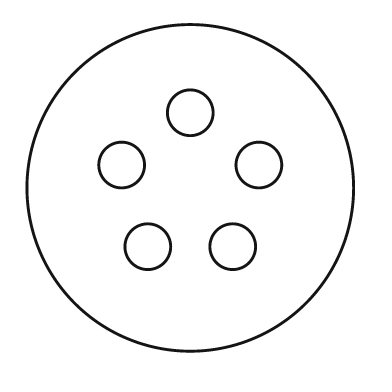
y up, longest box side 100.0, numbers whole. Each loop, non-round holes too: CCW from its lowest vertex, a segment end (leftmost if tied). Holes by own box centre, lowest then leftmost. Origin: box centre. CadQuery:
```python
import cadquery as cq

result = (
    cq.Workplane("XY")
    .moveTo(0.0, 0.0)
    .circle(50.0)
    .moveTo(-13.0, -18.0)
    .circle(7.0)
    .moveTo(13.0, -18.0)
    .circle(7.0)
    .moveTo(-21.0, 7.0)
    .circle(7.0)
    .moveTo(21.0, 7.0)
    .circle(7.0)
    .moveTo(0.0, 23.0)
    .circle(7.0)
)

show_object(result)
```